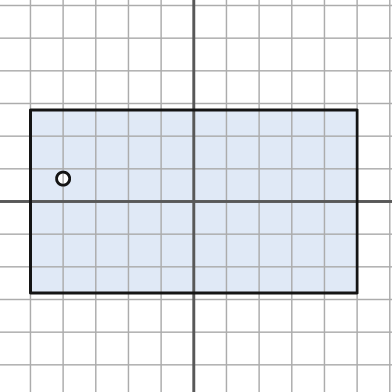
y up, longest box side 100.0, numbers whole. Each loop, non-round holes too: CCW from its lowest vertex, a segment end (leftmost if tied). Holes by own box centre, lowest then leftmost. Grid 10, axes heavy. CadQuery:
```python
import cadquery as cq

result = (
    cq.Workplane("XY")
    .moveTo(-50.0, -28.0)
    .lineTo(50.0, -28.0)
    .lineTo(50.0, 28.0)
    .lineTo(-50.0, 28.0)
    .close()
    .moveTo(-40.0, 7.0)
    .circle(2.0)
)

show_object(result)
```